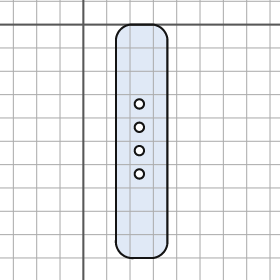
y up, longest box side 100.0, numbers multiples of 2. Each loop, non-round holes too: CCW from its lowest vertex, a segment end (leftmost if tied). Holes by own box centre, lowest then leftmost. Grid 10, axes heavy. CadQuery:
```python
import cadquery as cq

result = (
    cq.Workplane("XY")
    .moveTo(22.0, -100.0)
    .lineTo(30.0, -100.0)
    .threePointArc((34.0, -98.0), (36.0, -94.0))
    .lineTo(36.0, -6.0)
    .threePointArc((34.0, -2.0), (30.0, 0.0))
    .lineTo(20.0, 0.0)
    .threePointArc((16.0, -2.0), (14.0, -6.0))
    .lineTo(14.0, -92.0)
    .threePointArc((16.0, -98.0), (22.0, -100.0))
    .close()
    .moveTo(24.0, -64.0)
    .circle(2.0)
    .moveTo(24.0, -54.0)
    .circle(2.0)
    .moveTo(24.0, -44.0)
    .circle(2.0)
    .moveTo(24.0, -34.0)
    .circle(2.0)
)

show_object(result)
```